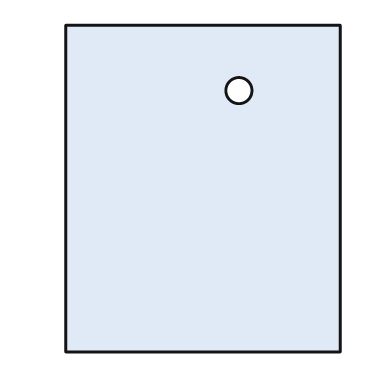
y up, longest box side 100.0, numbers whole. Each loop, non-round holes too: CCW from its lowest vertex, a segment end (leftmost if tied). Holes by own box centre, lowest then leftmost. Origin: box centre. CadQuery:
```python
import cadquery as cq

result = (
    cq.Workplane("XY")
    .moveTo(-42.0, -50.0)
    .lineTo(42.0, -50.0)
    .lineTo(42.0, 50.0)
    .lineTo(-42.0, 50.0)
    .close()
    .moveTo(11.0, 30.0)
    .circle(4.0)
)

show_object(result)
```